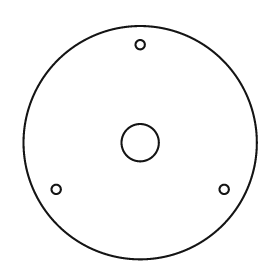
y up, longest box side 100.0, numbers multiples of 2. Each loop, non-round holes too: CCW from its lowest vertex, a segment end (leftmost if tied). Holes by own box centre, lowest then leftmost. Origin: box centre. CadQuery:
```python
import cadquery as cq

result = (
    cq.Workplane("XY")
    .moveTo(0.0, 0.0)
    .circle(50.0)
    .moveTo(-36.0, -20.0)
    .circle(2.0)
    .moveTo(36.0, -20.0)
    .circle(2.0)
    .moveTo(0.0, 0.0)
    .circle(8.0)
    .moveTo(0.0, 42.0)
    .circle(2.0)
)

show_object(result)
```